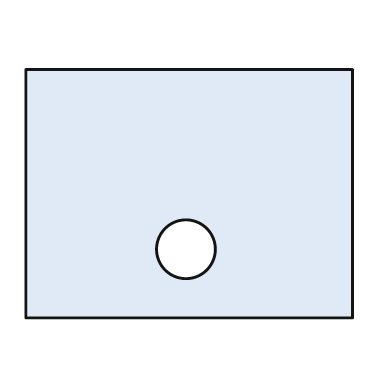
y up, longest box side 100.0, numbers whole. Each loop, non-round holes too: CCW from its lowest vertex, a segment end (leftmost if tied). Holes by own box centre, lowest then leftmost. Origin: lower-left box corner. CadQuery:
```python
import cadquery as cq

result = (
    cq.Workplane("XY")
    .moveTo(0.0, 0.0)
    .lineTo(100.0, 0.0)
    .lineTo(100.0, 76.0)
    .lineTo(0.0, 76.0)
    .close()
    .moveTo(49.0, 21.0)
    .circle(9.0)
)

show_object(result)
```